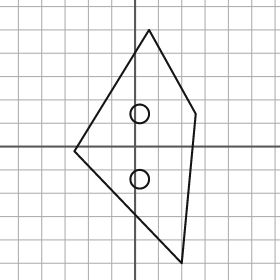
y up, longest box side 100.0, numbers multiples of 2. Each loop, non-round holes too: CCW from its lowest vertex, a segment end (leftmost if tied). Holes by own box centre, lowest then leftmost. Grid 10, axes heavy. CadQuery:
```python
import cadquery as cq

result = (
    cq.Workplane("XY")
    .moveTo(20.0, -50.0)
    .lineTo(26.0, 14.0)
    .lineTo(6.0, 50.0)
    .lineTo(-26.0, -2.0)
    .close()
    .moveTo(2.0, -14.0)
    .circle(4.0)
    .moveTo(2.0, 14.0)
    .circle(4.0)
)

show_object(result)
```